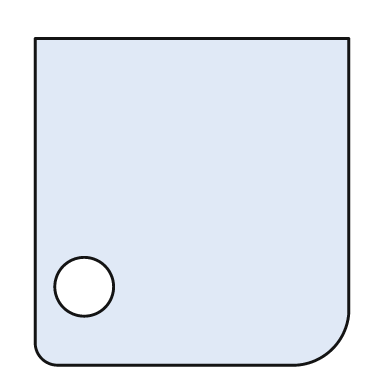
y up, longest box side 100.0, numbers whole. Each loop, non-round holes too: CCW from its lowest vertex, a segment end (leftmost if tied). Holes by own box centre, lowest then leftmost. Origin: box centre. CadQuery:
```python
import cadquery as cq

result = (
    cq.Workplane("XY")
    .moveTo(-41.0, -50.0)
    .lineTo(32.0, -50.0)
    .threePointArc((43.0, -45.0), (48.0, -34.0))
    .lineTo(48.0, 50.0)
    .lineTo(-48.0, 50.0)
    .lineTo(-48.0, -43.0)
    .threePointArc((-46.0, -48.0), (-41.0, -50.0))
    .close()
    .moveTo(-33.0, -26.0)
    .circle(9.0)
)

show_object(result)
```